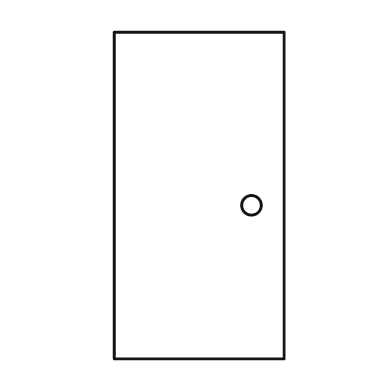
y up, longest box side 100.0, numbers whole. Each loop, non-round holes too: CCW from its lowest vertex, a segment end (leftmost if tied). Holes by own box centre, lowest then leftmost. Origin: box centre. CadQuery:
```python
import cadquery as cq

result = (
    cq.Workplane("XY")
    .moveTo(-26.0, -50.0)
    .lineTo(26.0, -50.0)
    .lineTo(26.0, 50.0)
    .lineTo(-26.0, 50.0)
    .close()
    .moveTo(16.0, -3.0)
    .circle(3.0)
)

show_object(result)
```